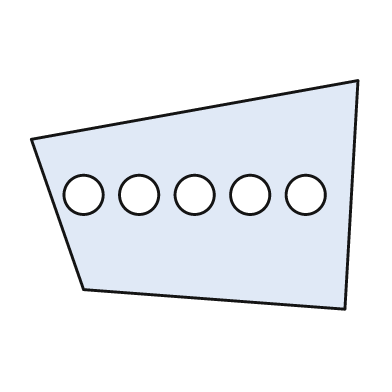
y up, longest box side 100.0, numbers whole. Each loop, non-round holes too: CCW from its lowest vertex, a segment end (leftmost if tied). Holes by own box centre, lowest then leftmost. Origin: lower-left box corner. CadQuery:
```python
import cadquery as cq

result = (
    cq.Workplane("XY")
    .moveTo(96.0, 0.0)
    .lineTo(100.0, 70.0)
    .lineTo(0.0, 52.0)
    .lineTo(16.0, 6.0)
    .close()
    .moveTo(16.0, 35.0)
    .circle(6.0)
    .moveTo(33.0, 35.0)
    .circle(6.0)
    .moveTo(50.0, 35.0)
    .circle(6.0)
    .moveTo(67.0, 35.0)
    .circle(6.0)
    .moveTo(84.0, 35.0)
    .circle(6.0)
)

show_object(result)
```